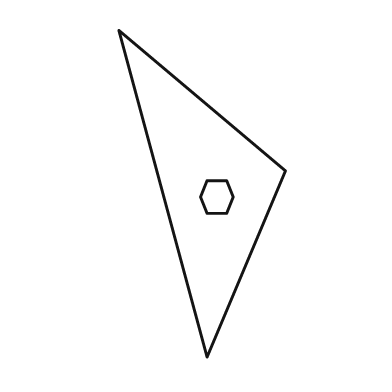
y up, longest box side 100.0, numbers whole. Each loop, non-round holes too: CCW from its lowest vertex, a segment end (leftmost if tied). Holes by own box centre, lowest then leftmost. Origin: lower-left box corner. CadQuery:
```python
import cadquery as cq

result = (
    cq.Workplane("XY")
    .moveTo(27.0, 0.0)
    .lineTo(51.0, 57.0)
    .lineTo(0.0, 100.0)
    .close()
    .moveTo(27.0, 44.0)
    .lineTo(33.0, 44.0)
    .lineTo(35.0, 49.0)
    .lineTo(33.0, 54.0)
    .lineTo(27.0, 54.0)
    .lineTo(25.0, 49.0)
    .close()
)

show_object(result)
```